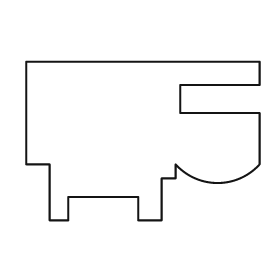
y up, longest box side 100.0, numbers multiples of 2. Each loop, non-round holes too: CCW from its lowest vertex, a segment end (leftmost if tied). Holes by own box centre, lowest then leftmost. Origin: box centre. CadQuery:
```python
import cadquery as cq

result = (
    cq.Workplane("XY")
    .moveTo(-40.0, -34.0)
    .lineTo(-32.0, -34.0)
    .lineTo(-32.0, -24.0)
    .lineTo(-2.0, -24.0)
    .lineTo(-2.0, -34.0)
    .lineTo(8.0, -34.0)
    .lineTo(8.0, -16.0)
    .lineTo(14.0, -16.0)
    .lineTo(14.0, -10.0)
    .threePointArc((32.0, -18.0), (50.0, -10.0))
    .lineTo(50.0, 12.0)
    .lineTo(16.0, 12.0)
    .lineTo(16.0, 24.0)
    .lineTo(50.0, 24.0)
    .lineTo(50.0, 34.0)
    .lineTo(-50.0, 34.0)
    .lineTo(-50.0, -10.0)
    .lineTo(-40.0, -10.0)
    .close()
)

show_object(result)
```